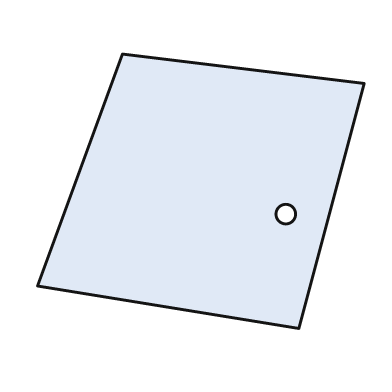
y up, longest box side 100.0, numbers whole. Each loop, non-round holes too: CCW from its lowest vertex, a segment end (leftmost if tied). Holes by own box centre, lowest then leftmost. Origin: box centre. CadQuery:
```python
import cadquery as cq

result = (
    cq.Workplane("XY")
    .moveTo(30.0, -42.0)
    .lineTo(50.0, 33.0)
    .lineTo(-24.0, 42.0)
    .lineTo(-50.0, -29.0)
    .close()
    .moveTo(26.0, -7.0)
    .circle(3.0)
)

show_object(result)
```